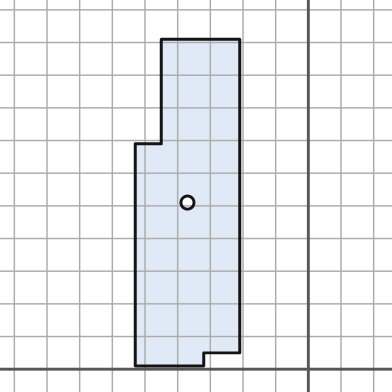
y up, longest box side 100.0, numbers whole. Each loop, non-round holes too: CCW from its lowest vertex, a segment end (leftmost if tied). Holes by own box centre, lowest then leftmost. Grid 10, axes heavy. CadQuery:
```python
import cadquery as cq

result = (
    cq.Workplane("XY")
    .moveTo(-53.0, 1.0)
    .lineTo(-32.0, 1.0)
    .lineTo(-32.0, 5.0)
    .lineTo(-21.0, 5.0)
    .lineTo(-21.0, 101.0)
    .lineTo(-45.0, 101.0)
    .lineTo(-45.0, 69.0)
    .lineTo(-53.0, 69.0)
    .close()
    .moveTo(-37.0, 51.0)
    .circle(2.0)
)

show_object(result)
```